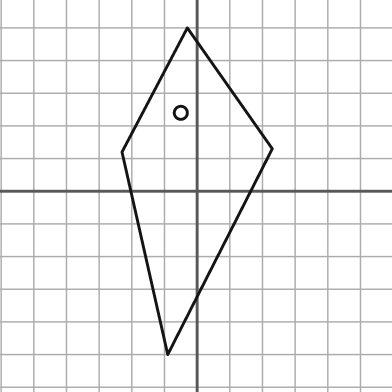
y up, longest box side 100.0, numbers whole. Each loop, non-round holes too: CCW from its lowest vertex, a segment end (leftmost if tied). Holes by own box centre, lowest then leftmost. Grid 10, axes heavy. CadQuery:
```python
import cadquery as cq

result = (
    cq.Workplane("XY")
    .moveTo(-9.0, -50.0)
    .lineTo(23.0, 13.0)
    .lineTo(-3.0, 50.0)
    .lineTo(-23.0, 12.0)
    .close()
    .moveTo(-5.0, 24.0)
    .circle(2.0)
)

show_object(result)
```